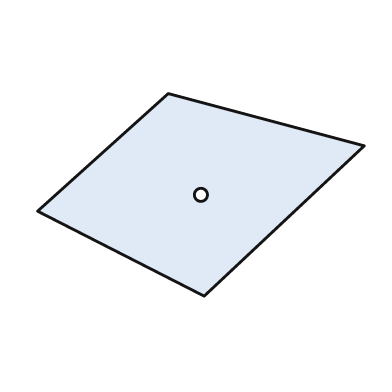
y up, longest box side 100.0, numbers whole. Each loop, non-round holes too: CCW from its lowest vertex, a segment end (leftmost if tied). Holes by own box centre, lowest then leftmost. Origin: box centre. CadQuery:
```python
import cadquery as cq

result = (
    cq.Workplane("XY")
    .moveTo(1.0, -31.0)
    .lineTo(50.0, 15.0)
    .lineTo(-10.0, 31.0)
    .lineTo(-50.0, -5.0)
    .close()
    .moveTo(0.0, 0.0)
    .circle(2.0)
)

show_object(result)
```